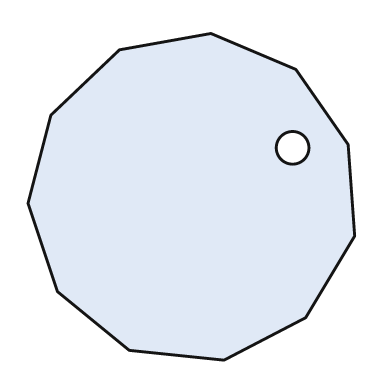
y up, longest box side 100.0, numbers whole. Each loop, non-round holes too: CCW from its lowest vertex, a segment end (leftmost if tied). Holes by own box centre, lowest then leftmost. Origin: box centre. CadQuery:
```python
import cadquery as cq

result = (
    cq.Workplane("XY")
    .moveTo(10.0, -50.0)
    .lineTo(35.0, -37.0)
    .lineTo(50.0, -12.0)
    .lineTo(48.0, 16.0)
    .lineTo(32.0, 39.0)
    .lineTo(6.0, 50.0)
    .lineTo(-22.0, 45.0)
    .lineTo(-43.0, 25.0)
    .lineTo(-50.0, -2.0)
    .lineTo(-41.0, -29.0)
    .lineTo(-19.0, -47.0)
    .close()
    .moveTo(31.0, 15.0)
    .circle(5.0)
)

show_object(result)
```